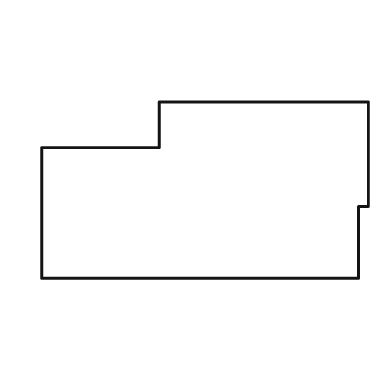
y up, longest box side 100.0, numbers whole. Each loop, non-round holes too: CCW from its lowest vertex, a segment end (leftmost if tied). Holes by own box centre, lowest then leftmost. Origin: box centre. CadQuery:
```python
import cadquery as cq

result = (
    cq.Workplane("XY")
    .moveTo(-50.0, -27.0)
    .lineTo(47.0, -27.0)
    .lineTo(47.0, -5.0)
    .lineTo(50.0, -5.0)
    .lineTo(50.0, 27.0)
    .lineTo(-14.0, 27.0)
    .lineTo(-14.0, 13.0)
    .lineTo(-50.0, 13.0)
    .close()
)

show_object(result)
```